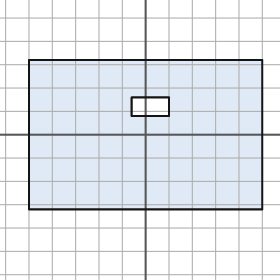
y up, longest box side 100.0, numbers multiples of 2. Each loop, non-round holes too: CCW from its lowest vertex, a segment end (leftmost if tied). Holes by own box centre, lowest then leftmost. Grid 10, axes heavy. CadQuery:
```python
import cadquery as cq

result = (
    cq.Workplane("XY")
    .moveTo(-50.0, -32.0)
    .lineTo(50.0, -32.0)
    .lineTo(50.0, 32.0)
    .lineTo(-50.0, 32.0)
    .close()
    .moveTo(-6.0, 8.0)
    .lineTo(10.0, 8.0)
    .lineTo(10.0, 16.0)
    .lineTo(-6.0, 16.0)
    .close()
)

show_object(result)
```